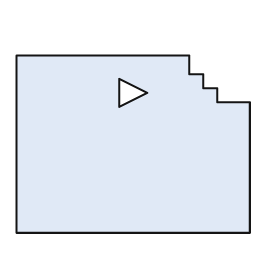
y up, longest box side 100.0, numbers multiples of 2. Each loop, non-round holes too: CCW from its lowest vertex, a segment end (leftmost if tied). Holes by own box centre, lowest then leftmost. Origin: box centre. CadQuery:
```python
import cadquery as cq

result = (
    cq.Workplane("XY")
    .moveTo(-50.0, -38.0)
    .lineTo(50.0, -38.0)
    .lineTo(50.0, 18.0)
    .lineTo(36.0, 18.0)
    .lineTo(36.0, 24.0)
    .lineTo(30.0, 24.0)
    .lineTo(30.0, 30.0)
    .lineTo(24.0, 30.0)
    .lineTo(24.0, 38.0)
    .lineTo(-50.0, 38.0)
    .close()
    .moveTo(-6.0, 16.0)
    .lineTo(6.0, 22.0)
    .lineTo(-6.0, 28.0)
    .close()
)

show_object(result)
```